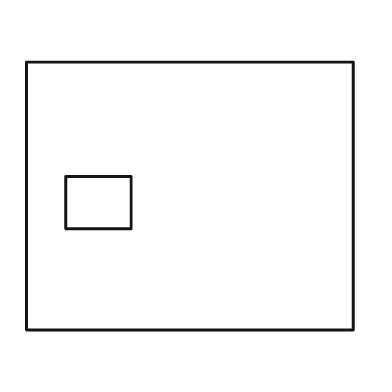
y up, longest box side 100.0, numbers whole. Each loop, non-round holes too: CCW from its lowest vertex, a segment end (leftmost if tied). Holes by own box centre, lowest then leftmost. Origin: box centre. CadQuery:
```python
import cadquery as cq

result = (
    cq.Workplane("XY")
    .moveTo(-50.0, -41.0)
    .lineTo(50.0, -41.0)
    .lineTo(50.0, 41.0)
    .lineTo(-50.0, 41.0)
    .close()
    .moveTo(-38.0, -10.0)
    .lineTo(-18.0, -10.0)
    .lineTo(-18.0, 6.0)
    .lineTo(-38.0, 6.0)
    .close()
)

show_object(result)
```